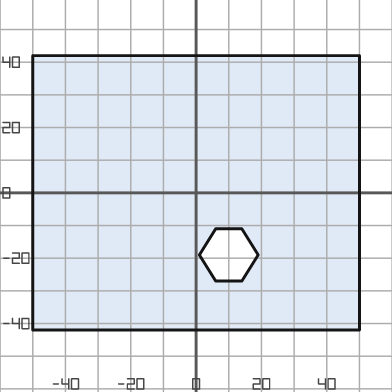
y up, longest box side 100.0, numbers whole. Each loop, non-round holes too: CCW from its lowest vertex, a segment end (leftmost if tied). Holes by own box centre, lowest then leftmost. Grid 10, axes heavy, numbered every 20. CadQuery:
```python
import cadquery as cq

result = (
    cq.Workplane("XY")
    .moveTo(-50.0, -42.0)
    .lineTo(50.0, -42.0)
    .lineTo(50.0, 42.0)
    .lineTo(-50.0, 42.0)
    .close()
    .moveTo(6.0, -27.0)
    .lineTo(14.0, -27.0)
    .lineTo(19.0, -19.0)
    .lineTo(14.0, -11.0)
    .lineTo(6.0, -11.0)
    .lineTo(1.0, -19.0)
    .close()
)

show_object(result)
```